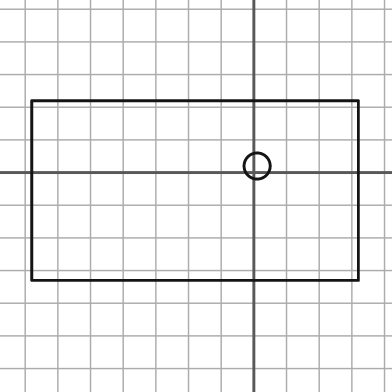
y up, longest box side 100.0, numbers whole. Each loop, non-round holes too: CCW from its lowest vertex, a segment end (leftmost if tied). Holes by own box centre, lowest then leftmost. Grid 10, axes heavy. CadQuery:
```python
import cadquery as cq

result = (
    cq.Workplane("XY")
    .moveTo(-68.0, -33.0)
    .lineTo(32.0, -33.0)
    .lineTo(32.0, 22.0)
    .lineTo(-68.0, 22.0)
    .close()
    .moveTo(1.0, 2.0)
    .circle(4.0)
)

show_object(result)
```